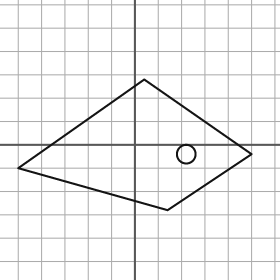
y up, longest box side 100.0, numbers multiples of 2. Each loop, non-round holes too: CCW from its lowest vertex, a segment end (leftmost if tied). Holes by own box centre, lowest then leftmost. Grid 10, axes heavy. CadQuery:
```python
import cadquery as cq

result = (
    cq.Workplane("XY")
    .moveTo(14.0, -28.0)
    .lineTo(50.0, -4.0)
    .lineTo(4.0, 28.0)
    .lineTo(-50.0, -10.0)
    .close()
    .moveTo(22.0, -4.0)
    .circle(4.0)
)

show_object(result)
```